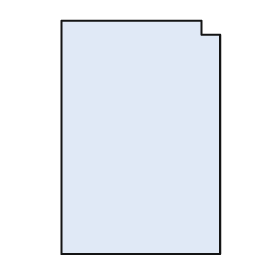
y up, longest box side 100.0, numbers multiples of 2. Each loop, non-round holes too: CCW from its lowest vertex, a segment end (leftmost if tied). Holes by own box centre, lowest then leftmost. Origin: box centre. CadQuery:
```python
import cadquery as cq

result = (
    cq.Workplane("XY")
    .moveTo(-34.0, -50.0)
    .lineTo(34.0, -50.0)
    .lineTo(34.0, 44.0)
    .lineTo(26.0, 44.0)
    .lineTo(26.0, 50.0)
    .lineTo(-34.0, 50.0)
    .close()
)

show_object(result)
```